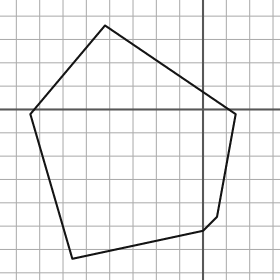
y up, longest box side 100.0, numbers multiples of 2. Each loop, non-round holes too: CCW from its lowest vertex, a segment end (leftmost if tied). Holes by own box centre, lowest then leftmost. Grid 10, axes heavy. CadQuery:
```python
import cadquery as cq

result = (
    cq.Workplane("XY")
    .moveTo(-56.0, -64.0)
    .lineTo(0.0, -52.0)
    .lineTo(6.0, -46.0)
    .lineTo(14.0, -2.0)
    .lineTo(-42.0, 36.0)
    .lineTo(-74.0, -2.0)
    .close()
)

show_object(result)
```